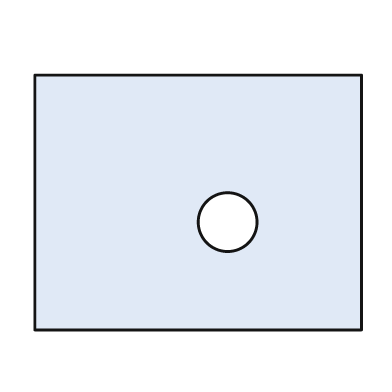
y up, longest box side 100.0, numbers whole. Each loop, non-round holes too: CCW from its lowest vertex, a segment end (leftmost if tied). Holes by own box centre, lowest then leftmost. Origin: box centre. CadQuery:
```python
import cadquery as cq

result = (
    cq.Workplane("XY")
    .moveTo(-50.0, -39.0)
    .lineTo(50.0, -39.0)
    .lineTo(50.0, 39.0)
    .lineTo(-50.0, 39.0)
    .close()
    .moveTo(9.0, -6.0)
    .circle(9.0)
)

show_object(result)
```